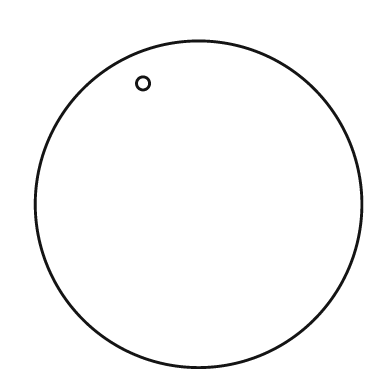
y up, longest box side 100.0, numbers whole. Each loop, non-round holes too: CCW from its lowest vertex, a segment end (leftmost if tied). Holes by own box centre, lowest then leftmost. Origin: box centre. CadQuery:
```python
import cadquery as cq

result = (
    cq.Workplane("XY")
    .moveTo(0.0, 0.0)
    .circle(50.0)
    .moveTo(-17.0, 37.0)
    .circle(2.0)
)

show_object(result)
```